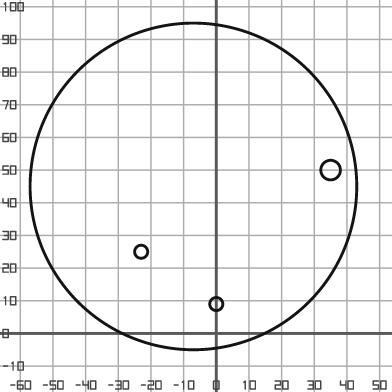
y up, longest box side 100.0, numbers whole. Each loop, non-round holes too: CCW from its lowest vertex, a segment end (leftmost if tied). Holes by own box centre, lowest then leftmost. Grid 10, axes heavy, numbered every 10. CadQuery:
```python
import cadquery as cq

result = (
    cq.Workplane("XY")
    .moveTo(-7.0, 45.0)
    .circle(50.0)
    .moveTo(0.0, 9.0)
    .circle(2.0)
    .moveTo(-23.0, 25.0)
    .circle(2.0)
    .moveTo(35.0, 50.0)
    .circle(3.0)
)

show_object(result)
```